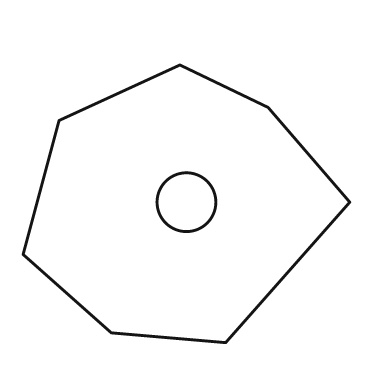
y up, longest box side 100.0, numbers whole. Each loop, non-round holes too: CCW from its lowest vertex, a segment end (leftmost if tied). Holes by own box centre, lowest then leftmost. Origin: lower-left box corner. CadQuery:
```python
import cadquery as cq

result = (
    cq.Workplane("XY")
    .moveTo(62.0, 0.0)
    .lineTo(100.0, 43.0)
    .lineTo(75.0, 72.0)
    .lineTo(48.0, 85.0)
    .lineTo(11.0, 68.0)
    .lineTo(0.0, 27.0)
    .lineTo(27.0, 3.0)
    .close()
    .moveTo(50.0, 43.0)
    .circle(9.0)
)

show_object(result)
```